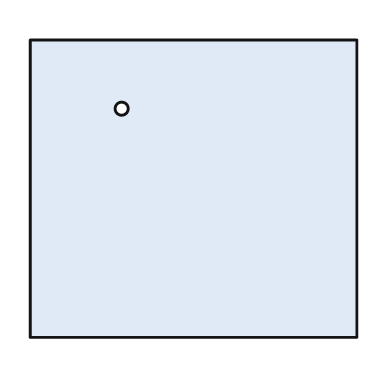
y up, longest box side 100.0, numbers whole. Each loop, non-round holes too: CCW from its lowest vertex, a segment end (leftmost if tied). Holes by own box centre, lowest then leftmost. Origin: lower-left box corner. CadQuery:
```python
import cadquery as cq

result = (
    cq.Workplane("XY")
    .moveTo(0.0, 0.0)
    .lineTo(100.0, 0.0)
    .lineTo(100.0, 91.0)
    .lineTo(0.0, 91.0)
    .close()
    .moveTo(28.0, 70.0)
    .circle(2.0)
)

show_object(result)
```